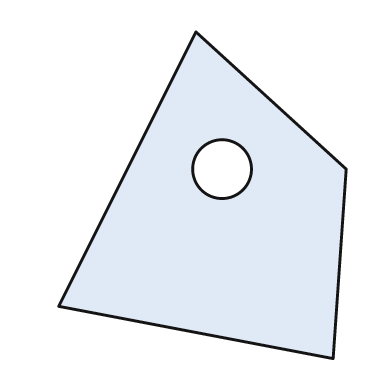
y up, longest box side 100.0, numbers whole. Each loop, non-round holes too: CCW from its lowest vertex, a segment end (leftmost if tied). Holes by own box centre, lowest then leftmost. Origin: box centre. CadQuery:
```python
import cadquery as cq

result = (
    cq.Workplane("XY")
    .moveTo(40.0, -50.0)
    .lineTo(44.0, 8.0)
    .lineTo(-2.0, 50.0)
    .lineTo(-44.0, -34.0)
    .close()
    .moveTo(6.0, 8.0)
    .circle(9.0)
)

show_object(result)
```